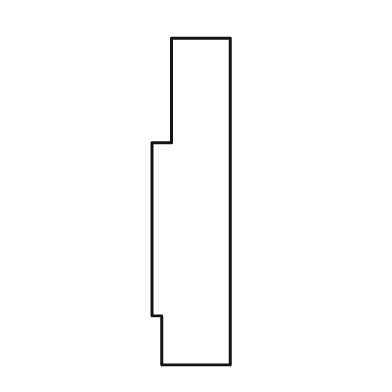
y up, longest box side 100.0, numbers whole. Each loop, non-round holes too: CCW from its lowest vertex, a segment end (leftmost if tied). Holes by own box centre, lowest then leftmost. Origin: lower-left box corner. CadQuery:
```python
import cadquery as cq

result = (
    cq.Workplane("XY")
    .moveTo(3.0, 0.0)
    .lineTo(24.0, 0.0)
    .lineTo(24.0, 100.0)
    .lineTo(6.0, 100.0)
    .lineTo(6.0, 68.0)
    .lineTo(0.0, 68.0)
    .lineTo(0.0, 15.0)
    .lineTo(3.0, 15.0)
    .close()
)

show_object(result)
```